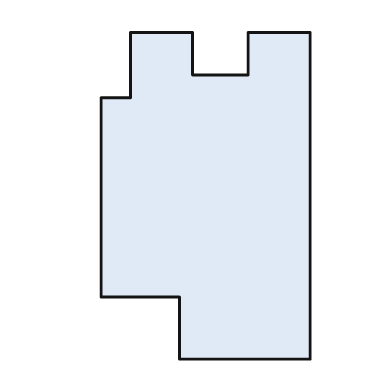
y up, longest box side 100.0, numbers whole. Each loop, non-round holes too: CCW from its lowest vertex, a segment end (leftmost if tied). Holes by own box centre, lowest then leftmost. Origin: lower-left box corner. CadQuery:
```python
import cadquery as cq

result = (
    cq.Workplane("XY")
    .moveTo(24.0, 0.0)
    .lineTo(64.0, 0.0)
    .lineTo(64.0, 100.0)
    .lineTo(45.0, 100.0)
    .lineTo(45.0, 87.0)
    .lineTo(28.0, 87.0)
    .lineTo(28.0, 100.0)
    .lineTo(9.0, 100.0)
    .lineTo(9.0, 80.0)
    .lineTo(0.0, 80.0)
    .lineTo(0.0, 19.0)
    .lineTo(24.0, 19.0)
    .close()
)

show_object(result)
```